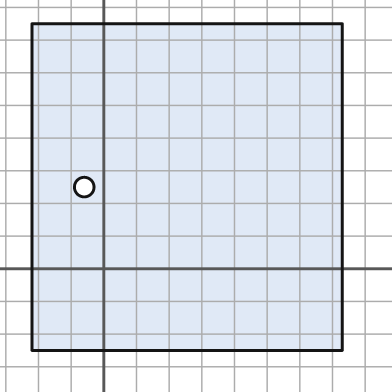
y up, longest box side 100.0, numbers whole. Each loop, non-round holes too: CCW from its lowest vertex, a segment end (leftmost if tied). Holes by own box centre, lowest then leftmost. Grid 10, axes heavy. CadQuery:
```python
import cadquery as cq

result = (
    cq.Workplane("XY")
    .moveTo(-22.0, -25.0)
    .lineTo(73.0, -25.0)
    .lineTo(73.0, 75.0)
    .lineTo(-22.0, 75.0)
    .close()
    .moveTo(-6.0, 25.0)
    .circle(3.0)
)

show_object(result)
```